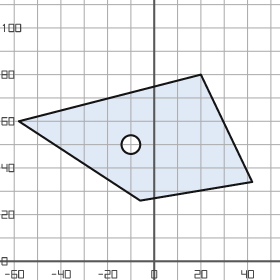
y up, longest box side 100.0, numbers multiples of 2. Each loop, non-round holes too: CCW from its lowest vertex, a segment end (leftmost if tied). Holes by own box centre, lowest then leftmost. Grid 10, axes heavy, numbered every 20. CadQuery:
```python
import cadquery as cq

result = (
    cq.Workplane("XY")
    .moveTo(-6.0, 26.0)
    .lineTo(42.0, 34.0)
    .lineTo(20.0, 80.0)
    .lineTo(-58.0, 60.0)
    .close()
    .moveTo(-10.0, 50.0)
    .circle(4.0)
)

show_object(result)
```